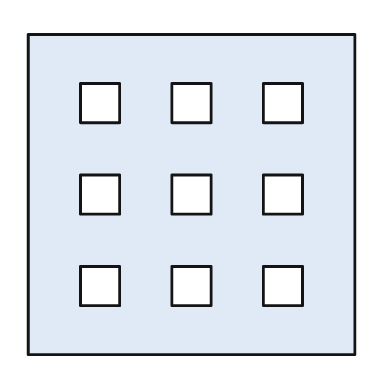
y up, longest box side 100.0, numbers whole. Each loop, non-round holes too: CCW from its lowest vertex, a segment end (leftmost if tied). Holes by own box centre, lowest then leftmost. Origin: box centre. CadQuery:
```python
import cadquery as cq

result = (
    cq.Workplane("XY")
    .moveTo(-50.0, -49.0)
    .lineTo(50.0, -49.0)
    .lineTo(50.0, 49.0)
    .lineTo(-50.0, 49.0)
    .close()
    .moveTo(-34.0, -34.0)
    .lineTo(-22.0, -34.0)
    .lineTo(-22.0, -22.0)
    .lineTo(-34.0, -22.0)
    .close()
    .moveTo(-6.0, -34.0)
    .lineTo(6.0, -34.0)
    .lineTo(6.0, -22.0)
    .lineTo(-6.0, -22.0)
    .close()
    .moveTo(22.0, -34.0)
    .lineTo(34.0, -34.0)
    .lineTo(34.0, -22.0)
    .lineTo(22.0, -22.0)
    .close()
    .moveTo(-34.0, -6.0)
    .lineTo(-22.0, -6.0)
    .lineTo(-22.0, 6.0)
    .lineTo(-34.0, 6.0)
    .close()
    .moveTo(-6.0, -6.0)
    .lineTo(6.0, -6.0)
    .lineTo(6.0, 6.0)
    .lineTo(-6.0, 6.0)
    .close()
    .moveTo(22.0, -6.0)
    .lineTo(34.0, -6.0)
    .lineTo(34.0, 6.0)
    .lineTo(22.0, 6.0)
    .close()
    .moveTo(-34.0, 22.0)
    .lineTo(-22.0, 22.0)
    .lineTo(-22.0, 34.0)
    .lineTo(-34.0, 34.0)
    .close()
    .moveTo(-6.0, 22.0)
    .lineTo(6.0, 22.0)
    .lineTo(6.0, 34.0)
    .lineTo(-6.0, 34.0)
    .close()
    .moveTo(22.0, 22.0)
    .lineTo(34.0, 22.0)
    .lineTo(34.0, 34.0)
    .lineTo(22.0, 34.0)
    .close()
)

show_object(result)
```